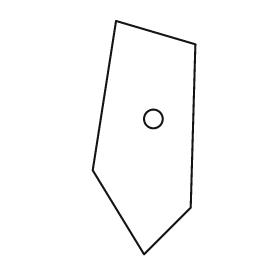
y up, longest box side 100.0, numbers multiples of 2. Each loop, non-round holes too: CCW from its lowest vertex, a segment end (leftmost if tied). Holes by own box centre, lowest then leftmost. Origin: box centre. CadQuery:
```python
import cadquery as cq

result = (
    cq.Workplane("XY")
    .moveTo(0.0, -50.0)
    .lineTo(20.0, -30.0)
    .lineTo(22.0, 40.0)
    .lineTo(-12.0, 50.0)
    .lineTo(-22.0, -14.0)
    .close()
    .moveTo(4.0, 8.0)
    .circle(4.0)
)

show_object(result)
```